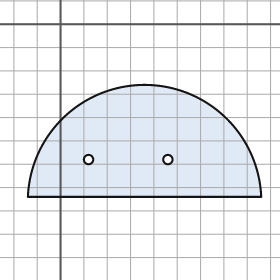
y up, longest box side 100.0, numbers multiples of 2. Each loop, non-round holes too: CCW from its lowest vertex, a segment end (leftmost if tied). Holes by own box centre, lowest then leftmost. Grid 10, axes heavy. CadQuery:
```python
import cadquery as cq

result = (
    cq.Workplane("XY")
    .moveTo(-14.0, -74.0)
    .lineTo(86.0, -74.0)
    .threePointArc((36.0, -26.0), (-14.0, -74.0))
    .close()
    .moveTo(12.0, -58.0)
    .circle(2.0)
    .moveTo(46.0, -58.0)
    .circle(2.0)
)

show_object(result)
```